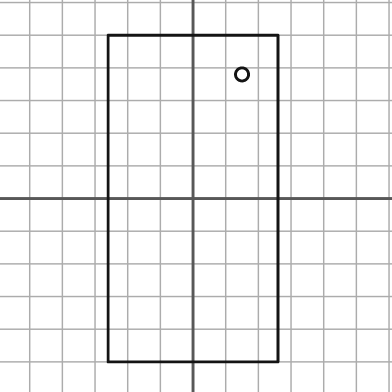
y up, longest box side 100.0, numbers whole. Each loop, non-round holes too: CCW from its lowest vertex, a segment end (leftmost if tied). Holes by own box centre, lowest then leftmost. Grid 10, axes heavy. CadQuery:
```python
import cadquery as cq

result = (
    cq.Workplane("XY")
    .moveTo(-26.0, -50.0)
    .lineTo(26.0, -50.0)
    .lineTo(26.0, 50.0)
    .lineTo(-26.0, 50.0)
    .close()
    .moveTo(15.0, 38.0)
    .circle(2.0)
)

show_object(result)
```